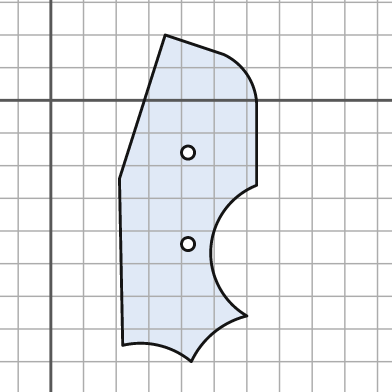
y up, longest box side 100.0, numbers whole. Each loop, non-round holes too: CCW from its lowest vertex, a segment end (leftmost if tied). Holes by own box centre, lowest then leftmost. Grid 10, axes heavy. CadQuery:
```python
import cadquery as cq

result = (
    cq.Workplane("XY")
    .moveTo(43.0, -80.0)
    .threePointArc((50.0, -71.0), (60.0, -66.0))
    .threePointArc((49.0, -45.0), (63.0, -26.0))
    .lineTo(63.0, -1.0)
    .threePointArc((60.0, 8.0), (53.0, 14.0))
    .lineTo(35.0, 20.0)
    .lineTo(21.0, -24.0)
    .lineTo(22.0, -75.0)
    .threePointArc((33.0, -75.0), (43.0, -80.0))
    .close()
    .moveTo(42.0, -44.0)
    .circle(2.0)
    .moveTo(42.0, -16.0)
    .circle(2.0)
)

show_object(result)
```